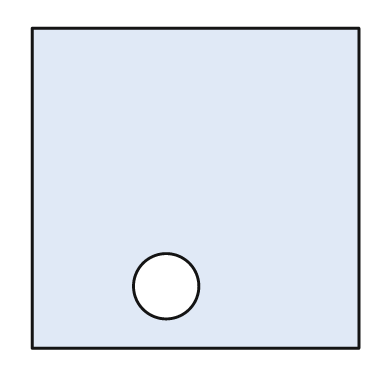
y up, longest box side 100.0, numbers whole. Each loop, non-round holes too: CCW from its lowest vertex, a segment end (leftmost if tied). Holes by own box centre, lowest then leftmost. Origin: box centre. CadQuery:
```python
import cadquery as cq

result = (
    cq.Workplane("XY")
    .moveTo(-50.0, -49.0)
    .lineTo(50.0, -49.0)
    .lineTo(50.0, 49.0)
    .lineTo(-50.0, 49.0)
    .close()
    .moveTo(-9.0, -30.0)
    .circle(10.0)
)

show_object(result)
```